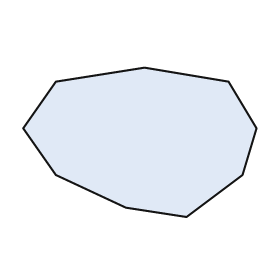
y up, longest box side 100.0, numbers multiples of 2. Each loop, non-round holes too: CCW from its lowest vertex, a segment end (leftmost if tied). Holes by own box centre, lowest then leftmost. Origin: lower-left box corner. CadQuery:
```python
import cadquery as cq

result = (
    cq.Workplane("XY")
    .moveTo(70.0, 0.0)
    .lineTo(94.0, 18.0)
    .lineTo(100.0, 38.0)
    .lineTo(88.0, 58.0)
    .lineTo(52.0, 64.0)
    .lineTo(14.0, 58.0)
    .lineTo(0.0, 38.0)
    .lineTo(14.0, 18.0)
    .lineTo(44.0, 4.0)
    .close()
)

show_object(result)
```